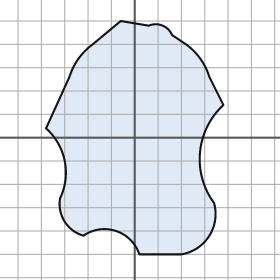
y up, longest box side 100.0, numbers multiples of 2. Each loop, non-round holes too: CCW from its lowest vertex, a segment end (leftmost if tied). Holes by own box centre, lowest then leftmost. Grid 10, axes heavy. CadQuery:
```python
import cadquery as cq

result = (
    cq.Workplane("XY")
    .moveTo(2.0, -50.0)
    .lineTo(20.0, -50.0)
    .threePointArc((32.0, -42.0), (34.0, -28.0))
    .threePointArc((28.0, -6.0), (38.0, 14.0))
    .lineTo(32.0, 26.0)
    .threePointArc((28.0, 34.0), (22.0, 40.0))
    .lineTo(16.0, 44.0)
    .threePointArc((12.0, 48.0), (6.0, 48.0))
    .lineTo(-6.0, 50.0)
    .lineTo(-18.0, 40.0)
    .threePointArc((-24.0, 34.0), (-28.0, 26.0))
    .lineTo(-38.0, 4.0)
    .threePointArc((-30.0, -10.0), (-32.0, -26.0))
    .threePointArc((-30.0, -36.0), (-22.0, -42.0))
    .threePointArc((-8.0, -40.0), (2.0, -50.0))
    .close()
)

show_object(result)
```